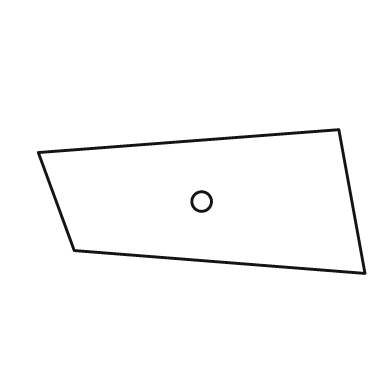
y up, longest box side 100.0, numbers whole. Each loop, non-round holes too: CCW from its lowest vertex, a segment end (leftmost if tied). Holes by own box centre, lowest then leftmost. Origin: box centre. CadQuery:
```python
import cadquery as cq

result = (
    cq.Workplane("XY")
    .moveTo(50.0, -22.0)
    .lineTo(42.0, 22.0)
    .lineTo(-50.0, 15.0)
    .lineTo(-39.0, -15.0)
    .close()
    .moveTo(0.0, 0.0)
    .circle(3.0)
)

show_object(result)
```